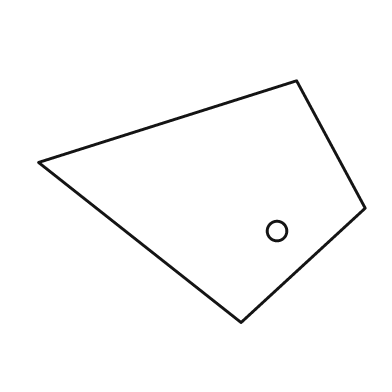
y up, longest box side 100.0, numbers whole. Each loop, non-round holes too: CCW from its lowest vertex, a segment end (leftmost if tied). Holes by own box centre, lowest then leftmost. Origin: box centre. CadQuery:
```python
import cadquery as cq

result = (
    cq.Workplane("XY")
    .moveTo(12.0, -37.0)
    .lineTo(50.0, -2.0)
    .lineTo(29.0, 37.0)
    .lineTo(-50.0, 12.0)
    .close()
    .moveTo(23.0, -9.0)
    .circle(3.0)
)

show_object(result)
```